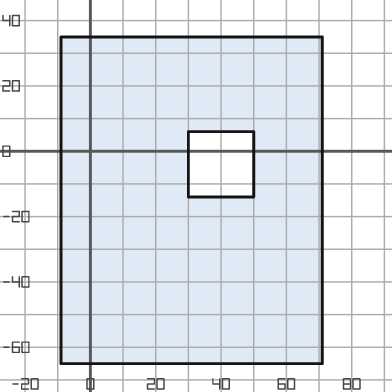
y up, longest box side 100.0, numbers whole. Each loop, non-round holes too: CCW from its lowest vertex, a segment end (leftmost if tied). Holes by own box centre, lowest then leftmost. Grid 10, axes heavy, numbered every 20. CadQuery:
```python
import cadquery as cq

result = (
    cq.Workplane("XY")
    .moveTo(-9.0, -65.0)
    .lineTo(71.0, -65.0)
    .lineTo(71.0, 35.0)
    .lineTo(-9.0, 35.0)
    .close()
    .moveTo(30.0, -14.0)
    .lineTo(50.0, -14.0)
    .lineTo(50.0, 6.0)
    .lineTo(30.0, 6.0)
    .close()
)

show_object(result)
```